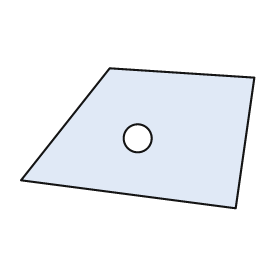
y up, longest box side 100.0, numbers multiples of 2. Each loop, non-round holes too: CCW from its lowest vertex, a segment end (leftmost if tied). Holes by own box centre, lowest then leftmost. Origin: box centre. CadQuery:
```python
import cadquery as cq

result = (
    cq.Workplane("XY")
    .moveTo(42.0, -30.0)
    .lineTo(50.0, 26.0)
    .lineTo(-12.0, 30.0)
    .lineTo(-50.0, -18.0)
    .close()
    .moveTo(0.0, 0.0)
    .circle(6.0)
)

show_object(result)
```